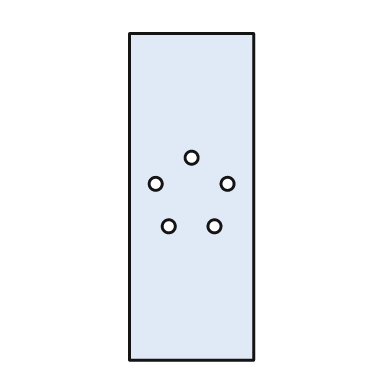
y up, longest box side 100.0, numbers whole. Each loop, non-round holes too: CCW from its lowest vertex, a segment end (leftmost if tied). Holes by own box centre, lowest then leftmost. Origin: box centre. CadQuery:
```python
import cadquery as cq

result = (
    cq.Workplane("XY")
    .moveTo(-19.0, -50.0)
    .lineTo(19.0, -50.0)
    .lineTo(19.0, 50.0)
    .lineTo(-19.0, 50.0)
    .close()
    .moveTo(-7.0, -9.0)
    .circle(2.0)
    .moveTo(7.0, -9.0)
    .circle(2.0)
    .moveTo(-11.0, 4.0)
    .circle(2.0)
    .moveTo(11.0, 4.0)
    .circle(2.0)
    .moveTo(0.0, 12.0)
    .circle(2.0)
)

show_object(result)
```